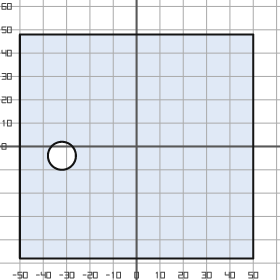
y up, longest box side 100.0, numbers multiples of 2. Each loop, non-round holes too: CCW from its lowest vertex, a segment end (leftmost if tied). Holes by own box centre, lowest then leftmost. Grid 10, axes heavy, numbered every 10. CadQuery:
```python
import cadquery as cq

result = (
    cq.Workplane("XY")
    .moveTo(-50.0, -48.0)
    .lineTo(50.0, -48.0)
    .lineTo(50.0, 48.0)
    .lineTo(-50.0, 48.0)
    .close()
    .moveTo(-32.0, -4.0)
    .circle(6.0)
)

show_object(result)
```